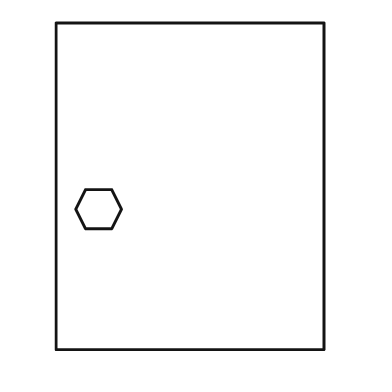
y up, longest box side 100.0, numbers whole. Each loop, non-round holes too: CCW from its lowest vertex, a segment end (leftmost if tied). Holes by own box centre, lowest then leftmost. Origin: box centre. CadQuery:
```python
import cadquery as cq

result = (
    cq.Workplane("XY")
    .moveTo(-41.0, -50.0)
    .lineTo(41.0, -50.0)
    .lineTo(41.0, 50.0)
    .lineTo(-41.0, 50.0)
    .close()
    .moveTo(-32.0, -13.0)
    .lineTo(-24.0, -13.0)
    .lineTo(-21.0, -7.0)
    .lineTo(-24.0, -1.0)
    .lineTo(-32.0, -1.0)
    .lineTo(-35.0, -7.0)
    .close()
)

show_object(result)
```